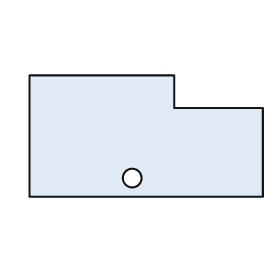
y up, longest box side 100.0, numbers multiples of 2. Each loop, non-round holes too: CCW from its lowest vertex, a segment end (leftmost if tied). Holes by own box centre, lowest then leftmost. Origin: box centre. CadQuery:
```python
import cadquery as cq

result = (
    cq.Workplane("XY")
    .moveTo(-50.0, -26.0)
    .lineTo(50.0, -26.0)
    .lineTo(50.0, 12.0)
    .lineTo(12.0, 12.0)
    .lineTo(12.0, 26.0)
    .lineTo(-50.0, 26.0)
    .close()
    .moveTo(-6.0, -18.0)
    .circle(4.0)
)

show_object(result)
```